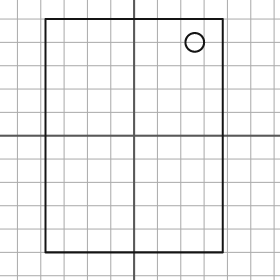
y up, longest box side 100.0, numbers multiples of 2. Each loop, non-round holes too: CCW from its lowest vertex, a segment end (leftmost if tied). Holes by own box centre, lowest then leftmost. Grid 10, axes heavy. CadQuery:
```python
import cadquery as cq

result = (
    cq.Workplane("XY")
    .moveTo(-38.0, -50.0)
    .lineTo(38.0, -50.0)
    .lineTo(38.0, 50.0)
    .lineTo(-38.0, 50.0)
    .close()
    .moveTo(26.0, 40.0)
    .circle(4.0)
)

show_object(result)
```